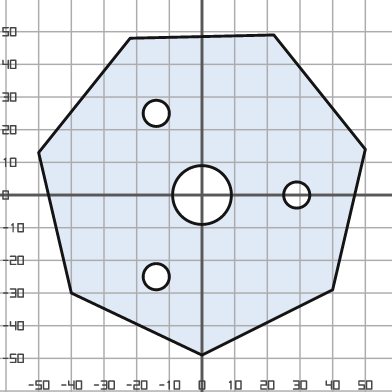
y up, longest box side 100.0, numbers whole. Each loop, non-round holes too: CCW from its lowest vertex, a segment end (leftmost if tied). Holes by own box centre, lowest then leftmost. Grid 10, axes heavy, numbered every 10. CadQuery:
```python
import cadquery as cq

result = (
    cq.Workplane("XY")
    .moveTo(0.0, -49.0)
    .lineTo(40.0, -29.0)
    .lineTo(50.0, 14.0)
    .lineTo(22.0, 49.0)
    .lineTo(-22.0, 48.0)
    .lineTo(-50.0, 13.0)
    .lineTo(-40.0, -30.0)
    .close()
    .moveTo(-14.0, -25.0)
    .circle(4.0)
    .moveTo(0.0, 0.0)
    .circle(9.0)
    .moveTo(29.0, 0.0)
    .circle(4.0)
    .moveTo(-14.0, 25.0)
    .circle(4.0)
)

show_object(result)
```